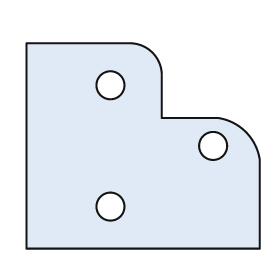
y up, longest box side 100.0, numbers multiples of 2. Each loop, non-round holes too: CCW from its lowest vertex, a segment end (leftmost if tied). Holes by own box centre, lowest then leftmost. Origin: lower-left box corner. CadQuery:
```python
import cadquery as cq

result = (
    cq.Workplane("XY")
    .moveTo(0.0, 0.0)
    .lineTo(100.0, 0.0)
    .lineTo(100.0, 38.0)
    .threePointArc((94.0, 50.0), (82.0, 56.0))
    .lineTo(58.0, 56.0)
    .lineTo(58.0, 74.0)
    .threePointArc((54.0, 84.0), (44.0, 88.0))
    .lineTo(0.0, 88.0)
    .close()
    .moveTo(36.0, 18.0)
    .circle(6.0)
    .moveTo(80.0, 44.0)
    .circle(6.0)
    .moveTo(36.0, 70.0)
    .circle(6.0)
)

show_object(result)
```